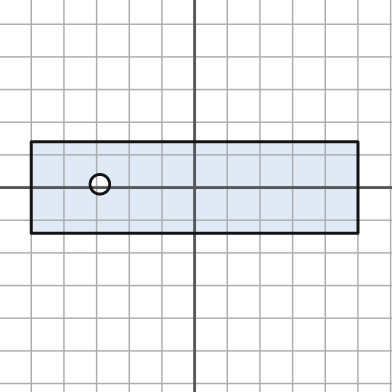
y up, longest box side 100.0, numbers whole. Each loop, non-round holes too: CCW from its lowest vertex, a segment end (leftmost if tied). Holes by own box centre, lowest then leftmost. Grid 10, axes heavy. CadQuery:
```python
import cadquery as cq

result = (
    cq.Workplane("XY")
    .moveTo(-50.0, -14.0)
    .lineTo(50.0, -14.0)
    .lineTo(50.0, 14.0)
    .lineTo(-50.0, 14.0)
    .close()
    .moveTo(-29.0, 1.0)
    .circle(3.0)
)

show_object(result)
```